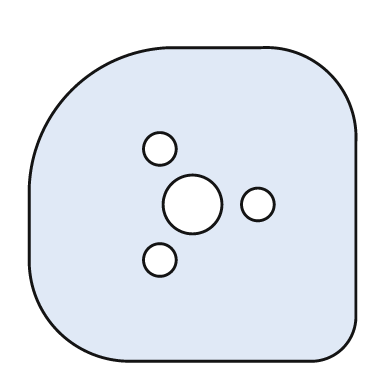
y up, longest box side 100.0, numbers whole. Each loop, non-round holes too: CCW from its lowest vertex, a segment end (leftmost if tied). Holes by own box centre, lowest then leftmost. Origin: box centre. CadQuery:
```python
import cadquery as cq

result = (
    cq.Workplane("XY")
    .moveTo(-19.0, -48.0)
    .lineTo(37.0, -48.0)
    .threePointArc((46.0, -44.0), (50.0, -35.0))
    .lineTo(50.0, 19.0)
    .threePointArc((42.0, 40.0), (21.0, 48.0))
    .lineTo(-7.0, 48.0)
    .threePointArc((-37.0, 35.0), (-50.0, 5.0))
    .lineTo(-50.0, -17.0)
    .threePointArc((-41.0, -39.0), (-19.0, -48.0))
    .close()
    .moveTo(-10.0, -17.0)
    .circle(5.0)
    .moveTo(0.0, 0.0)
    .circle(9.0)
    .moveTo(20.0, 0.0)
    .circle(5.0)
    .moveTo(-10.0, 17.0)
    .circle(5.0)
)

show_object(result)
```